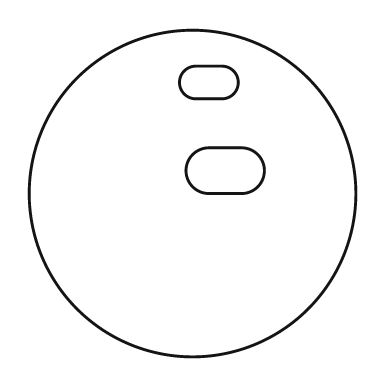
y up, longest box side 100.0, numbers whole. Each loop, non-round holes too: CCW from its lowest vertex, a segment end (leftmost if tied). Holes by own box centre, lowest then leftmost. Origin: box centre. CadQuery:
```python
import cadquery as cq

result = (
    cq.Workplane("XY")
    .moveTo(0.0, 0.0)
    .circle(50.0)
    .moveTo(5.0, 0.0)
    .lineTo(15.0, 0.0)
    .threePointArc((22.0, 7.0), (15.0, 14.0))
    .lineTo(5.0, 14.0)
    .threePointArc((-2.0, 7.0), (5.0, 0.0))
    .close()
    .moveTo(1.0, 29.0)
    .lineTo(9.0, 29.0)
    .threePointArc((14.0, 34.0), (9.0, 39.0))
    .lineTo(1.0, 39.0)
    .threePointArc((-4.0, 34.0), (1.0, 29.0))
    .close()
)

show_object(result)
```